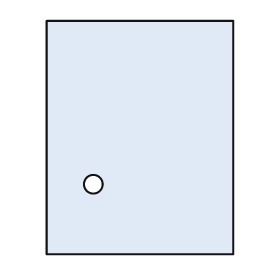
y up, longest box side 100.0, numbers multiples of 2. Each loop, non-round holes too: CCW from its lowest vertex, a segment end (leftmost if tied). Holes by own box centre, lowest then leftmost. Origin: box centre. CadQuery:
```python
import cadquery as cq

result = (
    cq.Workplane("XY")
    .moveTo(-40.0, -50.0)
    .lineTo(40.0, -50.0)
    .lineTo(40.0, 50.0)
    .lineTo(-40.0, 50.0)
    .close()
    .moveTo(-20.0, -20.0)
    .circle(4.0)
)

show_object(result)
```